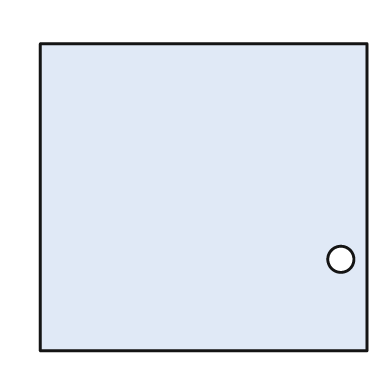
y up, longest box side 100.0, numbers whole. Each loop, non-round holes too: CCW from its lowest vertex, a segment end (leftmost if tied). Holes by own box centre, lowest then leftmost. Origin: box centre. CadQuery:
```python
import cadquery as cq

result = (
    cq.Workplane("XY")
    .moveTo(-50.0, -47.0)
    .lineTo(50.0, -47.0)
    .lineTo(50.0, 47.0)
    .lineTo(-50.0, 47.0)
    .close()
    .moveTo(42.0, -19.0)
    .circle(4.0)
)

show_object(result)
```